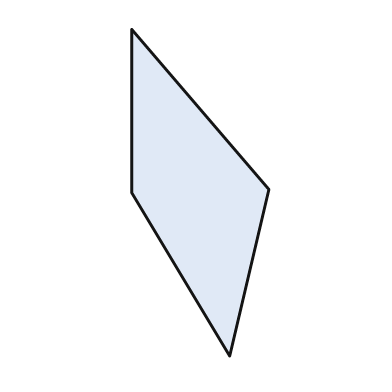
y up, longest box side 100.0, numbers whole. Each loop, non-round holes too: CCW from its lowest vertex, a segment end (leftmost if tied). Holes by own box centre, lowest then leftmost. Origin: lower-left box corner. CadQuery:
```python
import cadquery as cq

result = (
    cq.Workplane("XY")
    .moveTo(30.0, 0.0)
    .lineTo(42.0, 51.0)
    .lineTo(0.0, 100.0)
    .lineTo(0.0, 50.0)
    .close()
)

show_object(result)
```